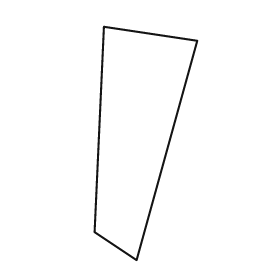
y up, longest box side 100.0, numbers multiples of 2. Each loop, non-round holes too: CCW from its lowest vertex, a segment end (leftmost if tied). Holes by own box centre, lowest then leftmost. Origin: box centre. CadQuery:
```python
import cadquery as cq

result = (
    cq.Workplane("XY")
    .moveTo(-4.0, -50.0)
    .lineTo(22.0, 44.0)
    .lineTo(-18.0, 50.0)
    .lineTo(-22.0, -38.0)
    .close()
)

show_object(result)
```